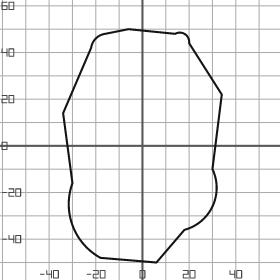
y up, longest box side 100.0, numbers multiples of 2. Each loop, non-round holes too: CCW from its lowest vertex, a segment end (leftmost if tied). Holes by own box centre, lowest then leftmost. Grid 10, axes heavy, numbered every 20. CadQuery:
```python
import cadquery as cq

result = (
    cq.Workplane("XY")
    .moveTo(6.0, -50.0)
    .lineTo(18.0, -36.0)
    .threePointArc((30.0, -26.0), (30.0, -10.0))
    .lineTo(34.0, 22.0)
    .lineTo(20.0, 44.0)
    .threePointArc((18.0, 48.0), (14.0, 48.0))
    .lineTo(-6.0, 50.0)
    .lineTo(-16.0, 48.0)
    .threePointArc((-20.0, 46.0), (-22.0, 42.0))
    .lineTo(-34.0, 14.0)
    .lineTo(-30.0, -16.0)
    .threePointArc((-30.0, -34.0), (-18.0, -48.0))
    .close()
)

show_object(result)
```